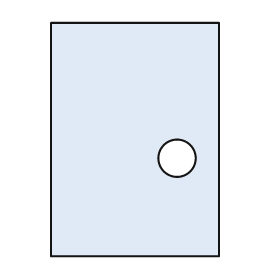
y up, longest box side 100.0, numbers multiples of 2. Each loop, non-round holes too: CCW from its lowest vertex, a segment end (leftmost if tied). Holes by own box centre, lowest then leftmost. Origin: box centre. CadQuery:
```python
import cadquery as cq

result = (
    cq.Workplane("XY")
    .moveTo(-36.0, -50.0)
    .lineTo(36.0, -50.0)
    .lineTo(36.0, 50.0)
    .lineTo(-36.0, 50.0)
    .close()
    .moveTo(18.0, -8.0)
    .circle(8.0)
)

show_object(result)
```